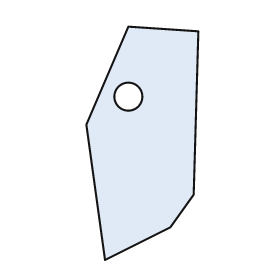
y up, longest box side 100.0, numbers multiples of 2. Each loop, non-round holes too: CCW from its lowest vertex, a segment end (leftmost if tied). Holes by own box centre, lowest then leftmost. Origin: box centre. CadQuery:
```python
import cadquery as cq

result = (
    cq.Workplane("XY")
    .moveTo(-16.0, -50.0)
    .lineTo(12.0, -36.0)
    .lineTo(22.0, -22.0)
    .lineTo(24.0, 48.0)
    .lineTo(-6.0, 50.0)
    .lineTo(-24.0, 8.0)
    .close()
    .moveTo(-6.0, 20.0)
    .circle(6.0)
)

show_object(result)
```